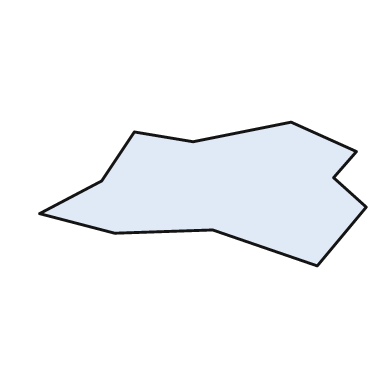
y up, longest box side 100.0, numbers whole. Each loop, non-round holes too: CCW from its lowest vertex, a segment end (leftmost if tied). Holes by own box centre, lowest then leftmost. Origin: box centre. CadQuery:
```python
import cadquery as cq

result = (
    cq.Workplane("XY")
    .moveTo(35.0, -22.0)
    .lineTo(50.0, -4.0)
    .lineTo(40.0, 5.0)
    .lineTo(47.0, 13.0)
    .lineTo(27.0, 22.0)
    .lineTo(-3.0, 16.0)
    .lineTo(-21.0, 19.0)
    .lineTo(-31.0, 4.0)
    .lineTo(-50.0, -6.0)
    .lineTo(-27.0, -12.0)
    .lineTo(3.0, -11.0)
    .close()
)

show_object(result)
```